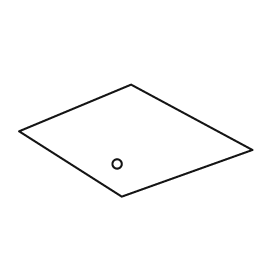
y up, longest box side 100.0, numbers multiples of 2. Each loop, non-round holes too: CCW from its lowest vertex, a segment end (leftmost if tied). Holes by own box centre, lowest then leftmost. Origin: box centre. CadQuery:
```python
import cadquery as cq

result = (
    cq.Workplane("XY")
    .moveTo(-6.0, -24.0)
    .lineTo(50.0, -4.0)
    .lineTo(-2.0, 24.0)
    .lineTo(-50.0, 4.0)
    .close()
    .moveTo(-8.0, -10.0)
    .circle(2.0)
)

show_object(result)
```